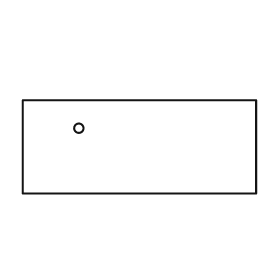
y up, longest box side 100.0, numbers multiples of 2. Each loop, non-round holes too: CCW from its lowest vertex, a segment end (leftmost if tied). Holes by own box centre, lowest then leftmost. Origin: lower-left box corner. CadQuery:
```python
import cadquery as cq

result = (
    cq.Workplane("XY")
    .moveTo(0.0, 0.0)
    .lineTo(100.0, 0.0)
    .lineTo(100.0, 40.0)
    .lineTo(0.0, 40.0)
    .close()
    .moveTo(24.0, 28.0)
    .circle(2.0)
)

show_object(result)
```